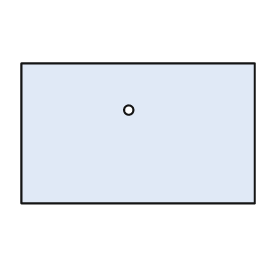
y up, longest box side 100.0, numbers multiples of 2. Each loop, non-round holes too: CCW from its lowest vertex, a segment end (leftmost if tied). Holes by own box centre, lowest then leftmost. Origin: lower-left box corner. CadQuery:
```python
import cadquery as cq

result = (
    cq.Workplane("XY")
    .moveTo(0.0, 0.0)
    .lineTo(100.0, 0.0)
    .lineTo(100.0, 60.0)
    .lineTo(0.0, 60.0)
    .close()
    .moveTo(46.0, 40.0)
    .circle(2.0)
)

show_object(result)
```